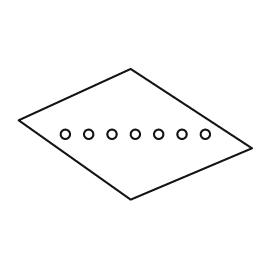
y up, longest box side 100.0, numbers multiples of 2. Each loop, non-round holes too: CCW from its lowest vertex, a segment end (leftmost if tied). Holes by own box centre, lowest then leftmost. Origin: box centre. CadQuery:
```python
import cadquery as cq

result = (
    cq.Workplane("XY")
    .moveTo(-2.0, -28.0)
    .lineTo(50.0, -6.0)
    .lineTo(-2.0, 28.0)
    .lineTo(-50.0, 6.0)
    .close()
    .moveTo(-30.0, 0.0)
    .circle(2.0)
    .moveTo(-20.0, 0.0)
    .circle(2.0)
    .moveTo(-10.0, 0.0)
    .circle(2.0)
    .moveTo(0.0, 0.0)
    .circle(2.0)
    .moveTo(10.0, 0.0)
    .circle(2.0)
    .moveTo(20.0, 0.0)
    .circle(2.0)
    .moveTo(30.0, 0.0)
    .circle(2.0)
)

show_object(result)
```